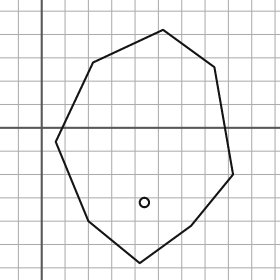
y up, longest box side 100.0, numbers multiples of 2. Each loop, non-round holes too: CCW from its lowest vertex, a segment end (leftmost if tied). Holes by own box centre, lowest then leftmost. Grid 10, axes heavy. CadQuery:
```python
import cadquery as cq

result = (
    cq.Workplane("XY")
    .moveTo(42.0, -58.0)
    .lineTo(64.0, -42.0)
    .lineTo(82.0, -20.0)
    .lineTo(74.0, 26.0)
    .lineTo(52.0, 42.0)
    .lineTo(22.0, 28.0)
    .lineTo(6.0, -6.0)
    .lineTo(20.0, -40.0)
    .close()
    .moveTo(44.0, -32.0)
    .circle(2.0)
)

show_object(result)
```